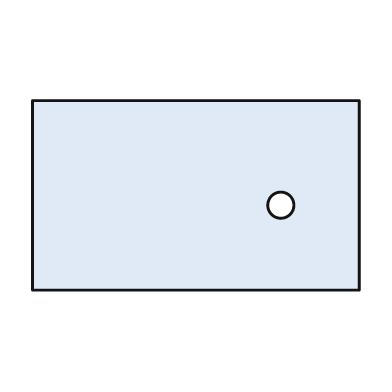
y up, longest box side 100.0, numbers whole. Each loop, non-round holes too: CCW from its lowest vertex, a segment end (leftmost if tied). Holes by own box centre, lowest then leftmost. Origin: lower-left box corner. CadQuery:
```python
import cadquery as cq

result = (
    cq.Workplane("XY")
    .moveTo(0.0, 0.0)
    .lineTo(100.0, 0.0)
    .lineTo(100.0, 58.0)
    .lineTo(0.0, 58.0)
    .close()
    .moveTo(76.0, 26.0)
    .circle(4.0)
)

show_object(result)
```